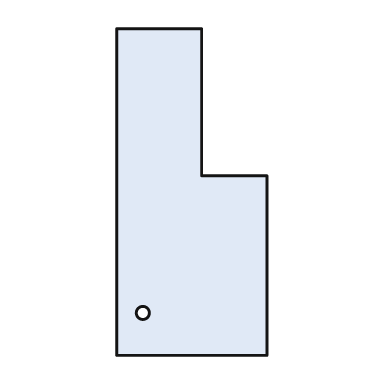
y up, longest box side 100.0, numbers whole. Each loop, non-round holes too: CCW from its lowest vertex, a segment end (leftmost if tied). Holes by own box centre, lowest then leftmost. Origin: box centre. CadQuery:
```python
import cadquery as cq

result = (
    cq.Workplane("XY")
    .moveTo(-23.0, -50.0)
    .lineTo(23.0, -50.0)
    .lineTo(23.0, 5.0)
    .lineTo(3.0, 5.0)
    .lineTo(3.0, 50.0)
    .lineTo(-23.0, 50.0)
    .close()
    .moveTo(-15.0, -37.0)
    .circle(2.0)
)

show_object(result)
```